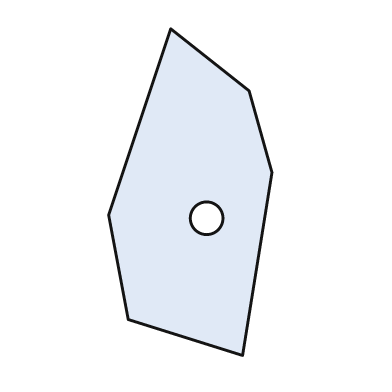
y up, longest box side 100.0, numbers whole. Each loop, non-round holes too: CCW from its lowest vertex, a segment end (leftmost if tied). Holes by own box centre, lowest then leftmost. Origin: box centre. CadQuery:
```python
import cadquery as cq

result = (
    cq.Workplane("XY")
    .moveTo(16.0, -50.0)
    .lineTo(25.0, 6.0)
    .lineTo(18.0, 31.0)
    .lineTo(-6.0, 50.0)
    .lineTo(-25.0, -7.0)
    .lineTo(-19.0, -39.0)
    .close()
    .moveTo(5.0, -8.0)
    .circle(5.0)
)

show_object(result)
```